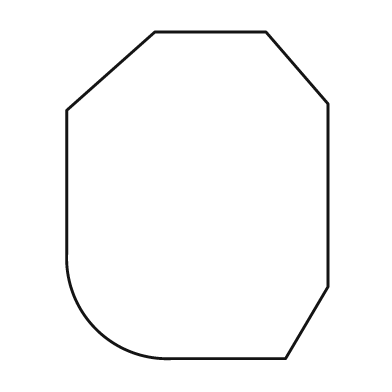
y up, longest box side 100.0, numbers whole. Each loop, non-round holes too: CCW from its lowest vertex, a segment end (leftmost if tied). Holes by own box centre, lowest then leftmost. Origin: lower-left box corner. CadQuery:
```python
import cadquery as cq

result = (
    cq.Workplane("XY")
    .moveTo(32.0, 0.0)
    .lineTo(67.0, 0.0)
    .lineTo(80.0, 22.0)
    .lineTo(80.0, 78.0)
    .lineTo(61.0, 100.0)
    .lineTo(27.0, 100.0)
    .lineTo(0.0, 76.0)
    .lineTo(0.0, 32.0)
    .threePointArc((9.0, 9.0), (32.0, 0.0))
    .close()
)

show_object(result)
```